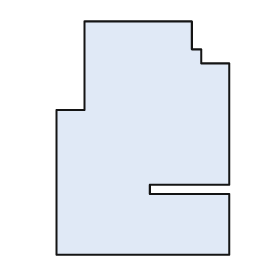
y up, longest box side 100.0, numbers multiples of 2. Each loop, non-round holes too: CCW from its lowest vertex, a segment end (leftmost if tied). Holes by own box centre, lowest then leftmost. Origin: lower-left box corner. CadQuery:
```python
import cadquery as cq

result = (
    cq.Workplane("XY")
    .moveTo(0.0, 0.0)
    .lineTo(74.0, 0.0)
    .lineTo(74.0, 26.0)
    .lineTo(40.0, 26.0)
    .lineTo(40.0, 30.0)
    .lineTo(74.0, 30.0)
    .lineTo(74.0, 82.0)
    .lineTo(62.0, 82.0)
    .lineTo(62.0, 88.0)
    .lineTo(58.0, 88.0)
    .lineTo(58.0, 100.0)
    .lineTo(12.0, 100.0)
    .lineTo(12.0, 62.0)
    .lineTo(0.0, 62.0)
    .close()
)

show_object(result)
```